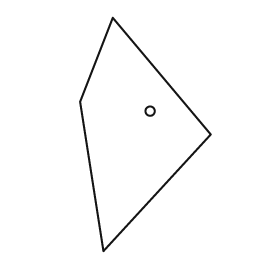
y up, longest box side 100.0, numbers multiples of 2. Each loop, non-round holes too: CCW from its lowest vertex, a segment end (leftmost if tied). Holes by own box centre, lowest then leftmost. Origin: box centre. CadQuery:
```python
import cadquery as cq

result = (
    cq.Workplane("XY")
    .moveTo(-18.0, -50.0)
    .lineTo(28.0, 0.0)
    .lineTo(-14.0, 50.0)
    .lineTo(-28.0, 14.0)
    .close()
    .moveTo(2.0, 10.0)
    .circle(2.0)
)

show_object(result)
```